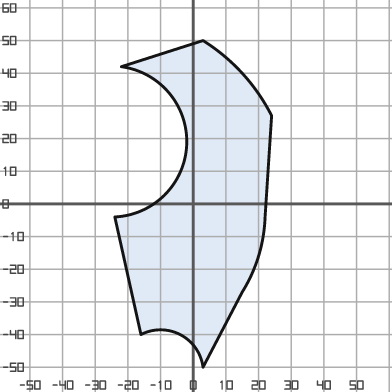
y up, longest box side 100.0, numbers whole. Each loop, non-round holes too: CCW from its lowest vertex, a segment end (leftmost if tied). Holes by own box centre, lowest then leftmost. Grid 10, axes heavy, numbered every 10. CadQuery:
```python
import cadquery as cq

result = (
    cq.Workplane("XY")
    .moveTo(3.0, -50.0)
    .lineTo(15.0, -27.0)
    .threePointArc((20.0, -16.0), (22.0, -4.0))
    .lineTo(24.0, 27.0)
    .threePointArc((15.0, 40.0), (3.0, 50.0))
    .lineTo(-22.0, 42.0)
    .threePointArc((-2.0, 18.0), (-24.0, -4.0))
    .lineTo(-16.0, -40.0)
    .threePointArc((-4.0, -40.0), (3.0, -50.0))
    .close()
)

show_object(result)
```